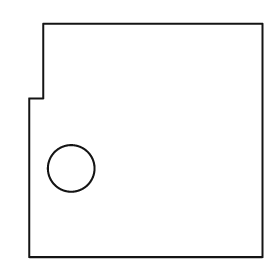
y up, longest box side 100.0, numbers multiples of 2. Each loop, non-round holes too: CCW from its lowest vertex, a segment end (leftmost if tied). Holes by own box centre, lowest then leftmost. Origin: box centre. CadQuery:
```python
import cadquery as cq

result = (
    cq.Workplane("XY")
    .moveTo(-50.0, -50.0)
    .lineTo(50.0, -50.0)
    .lineTo(50.0, 50.0)
    .lineTo(-44.0, 50.0)
    .lineTo(-44.0, 18.0)
    .lineTo(-50.0, 18.0)
    .close()
    .moveTo(-32.0, -12.0)
    .circle(10.0)
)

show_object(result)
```